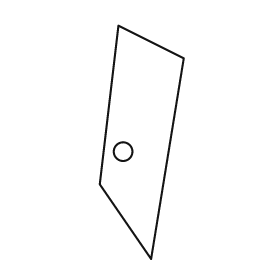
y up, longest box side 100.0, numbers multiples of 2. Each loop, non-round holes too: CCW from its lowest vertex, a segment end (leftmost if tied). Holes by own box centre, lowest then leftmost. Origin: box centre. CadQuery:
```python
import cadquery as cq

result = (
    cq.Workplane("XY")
    .moveTo(4.0, -50.0)
    .lineTo(18.0, 36.0)
    .lineTo(-10.0, 50.0)
    .lineTo(-18.0, -18.0)
    .close()
    .moveTo(-8.0, -4.0)
    .circle(4.0)
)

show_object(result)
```